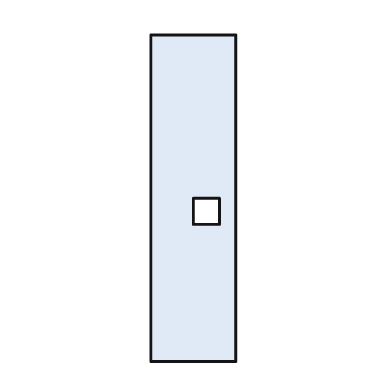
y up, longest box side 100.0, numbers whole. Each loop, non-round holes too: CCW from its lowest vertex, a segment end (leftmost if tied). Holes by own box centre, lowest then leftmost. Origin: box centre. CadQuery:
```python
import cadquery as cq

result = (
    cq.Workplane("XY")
    .moveTo(-13.0, -50.0)
    .lineTo(13.0, -50.0)
    .lineTo(13.0, 50.0)
    .lineTo(-13.0, 50.0)
    .close()
    .moveTo(0.0, -8.0)
    .lineTo(8.0, -8.0)
    .lineTo(8.0, 0.0)
    .lineTo(0.0, 0.0)
    .close()
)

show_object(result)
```